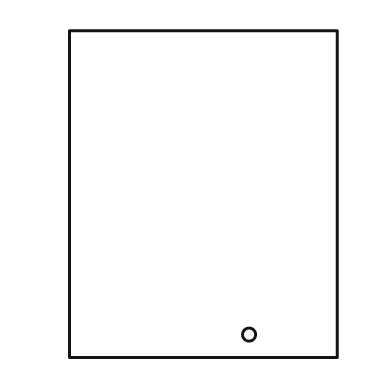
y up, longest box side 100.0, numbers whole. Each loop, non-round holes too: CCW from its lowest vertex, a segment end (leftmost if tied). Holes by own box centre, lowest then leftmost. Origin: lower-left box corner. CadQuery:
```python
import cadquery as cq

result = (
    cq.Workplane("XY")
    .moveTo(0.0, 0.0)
    .lineTo(82.0, 0.0)
    .lineTo(82.0, 100.0)
    .lineTo(0.0, 100.0)
    .close()
    .moveTo(55.0, 7.0)
    .circle(2.0)
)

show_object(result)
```